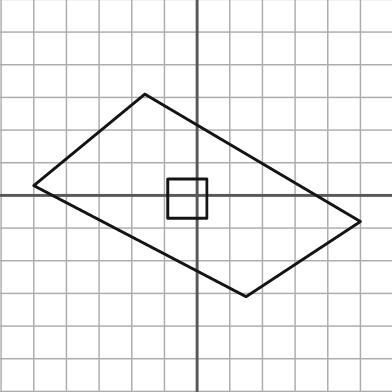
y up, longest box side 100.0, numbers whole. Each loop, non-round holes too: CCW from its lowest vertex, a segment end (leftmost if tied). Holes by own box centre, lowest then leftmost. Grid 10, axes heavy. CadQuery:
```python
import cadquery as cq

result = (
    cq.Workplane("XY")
    .moveTo(15.0, -31.0)
    .lineTo(50.0, -8.0)
    .lineTo(-16.0, 31.0)
    .lineTo(-50.0, 3.0)
    .close()
    .moveTo(-9.0, -7.0)
    .lineTo(3.0, -7.0)
    .lineTo(3.0, 5.0)
    .lineTo(-9.0, 5.0)
    .close()
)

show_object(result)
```